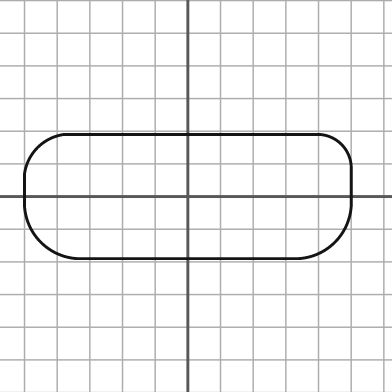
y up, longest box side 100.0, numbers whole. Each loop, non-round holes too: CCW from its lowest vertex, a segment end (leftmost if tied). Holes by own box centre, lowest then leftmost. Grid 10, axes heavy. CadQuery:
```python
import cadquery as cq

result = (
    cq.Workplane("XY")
    .moveTo(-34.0, -19.0)
    .lineTo(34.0, -19.0)
    .threePointArc((45.0, -14.0), (50.0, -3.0))
    .lineTo(50.0, 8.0)
    .threePointArc((47.0, 16.0), (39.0, 19.0))
    .lineTo(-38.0, 19.0)
    .threePointArc((-46.0, 15.0), (-50.0, 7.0))
    .lineTo(-50.0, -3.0)
    .threePointArc((-45.0, -14.0), (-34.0, -19.0))
    .close()
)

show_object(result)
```